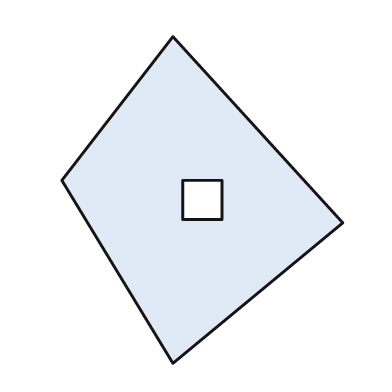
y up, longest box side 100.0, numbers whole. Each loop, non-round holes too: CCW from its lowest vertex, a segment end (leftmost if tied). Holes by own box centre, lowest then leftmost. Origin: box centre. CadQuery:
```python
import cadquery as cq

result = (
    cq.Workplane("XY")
    .moveTo(-9.0, -50.0)
    .lineTo(43.0, -7.0)
    .lineTo(-9.0, 50.0)
    .lineTo(-43.0, 6.0)
    .close()
    .moveTo(-6.0, -6.0)
    .lineTo(6.0, -6.0)
    .lineTo(6.0, 6.0)
    .lineTo(-6.0, 6.0)
    .close()
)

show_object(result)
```